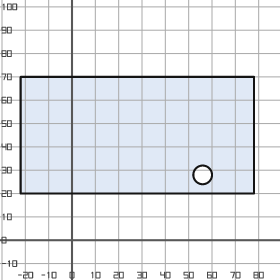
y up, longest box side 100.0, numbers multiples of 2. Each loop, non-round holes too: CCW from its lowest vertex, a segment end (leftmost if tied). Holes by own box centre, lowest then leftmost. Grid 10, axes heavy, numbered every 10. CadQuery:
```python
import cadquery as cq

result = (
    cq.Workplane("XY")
    .moveTo(-22.0, 20.0)
    .lineTo(78.0, 20.0)
    .lineTo(78.0, 70.0)
    .lineTo(-22.0, 70.0)
    .close()
    .moveTo(56.0, 28.0)
    .circle(4.0)
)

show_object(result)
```